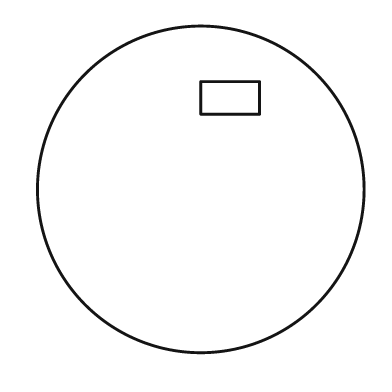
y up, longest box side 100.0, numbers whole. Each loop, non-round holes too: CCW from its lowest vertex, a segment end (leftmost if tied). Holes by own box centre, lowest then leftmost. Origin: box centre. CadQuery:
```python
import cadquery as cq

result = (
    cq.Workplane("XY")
    .moveTo(0.0, 0.0)
    .circle(50.0)
    .moveTo(0.0, 23.0)
    .lineTo(18.0, 23.0)
    .lineTo(18.0, 33.0)
    .lineTo(0.0, 33.0)
    .close()
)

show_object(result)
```